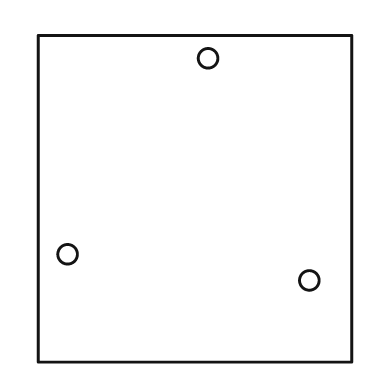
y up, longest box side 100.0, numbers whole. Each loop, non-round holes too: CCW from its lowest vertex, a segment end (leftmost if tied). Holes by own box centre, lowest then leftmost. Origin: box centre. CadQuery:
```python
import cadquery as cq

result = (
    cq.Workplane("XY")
    .moveTo(-48.0, -50.0)
    .lineTo(48.0, -50.0)
    .lineTo(48.0, 50.0)
    .lineTo(-48.0, 50.0)
    .close()
    .moveTo(35.0, -25.0)
    .circle(3.0)
    .moveTo(-39.0, -17.0)
    .circle(3.0)
    .moveTo(4.0, 43.0)
    .circle(3.0)
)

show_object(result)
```